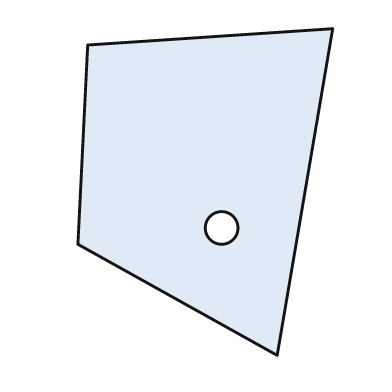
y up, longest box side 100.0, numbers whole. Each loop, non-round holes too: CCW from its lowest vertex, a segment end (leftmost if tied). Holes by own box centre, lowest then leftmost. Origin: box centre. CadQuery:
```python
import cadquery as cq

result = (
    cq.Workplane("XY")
    .moveTo(22.0, -50.0)
    .lineTo(39.0, 50.0)
    .lineTo(-36.0, 45.0)
    .lineTo(-39.0, -16.0)
    .close()
    .moveTo(5.0, -11.0)
    .circle(5.0)
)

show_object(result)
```